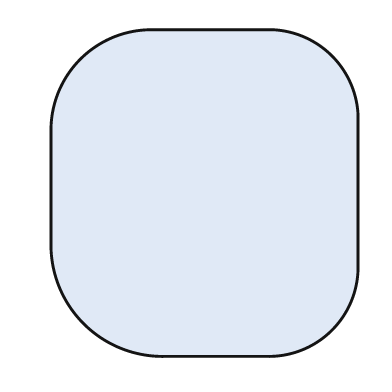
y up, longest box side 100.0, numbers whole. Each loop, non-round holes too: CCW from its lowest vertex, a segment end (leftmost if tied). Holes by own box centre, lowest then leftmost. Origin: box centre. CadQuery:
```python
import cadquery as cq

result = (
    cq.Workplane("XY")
    .moveTo(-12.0, -50.0)
    .lineTo(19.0, -50.0)
    .threePointArc((39.0, -42.0), (47.0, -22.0))
    .lineTo(47.0, 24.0)
    .threePointArc((39.0, 42.0), (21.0, 50.0))
    .lineTo(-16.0, 50.0)
    .threePointArc((-38.0, 41.0), (-47.0, 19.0))
    .lineTo(-47.0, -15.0)
    .threePointArc((-37.0, -40.0), (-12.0, -50.0))
    .close()
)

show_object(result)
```